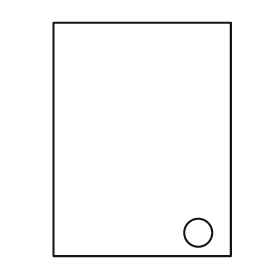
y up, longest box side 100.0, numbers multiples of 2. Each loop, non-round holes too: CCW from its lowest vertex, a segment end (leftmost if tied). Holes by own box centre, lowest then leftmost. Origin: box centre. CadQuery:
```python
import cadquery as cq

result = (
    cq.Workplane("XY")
    .moveTo(-38.0, -50.0)
    .lineTo(38.0, -50.0)
    .lineTo(38.0, 50.0)
    .lineTo(-38.0, 50.0)
    .close()
    .moveTo(24.0, -40.0)
    .circle(6.0)
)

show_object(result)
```